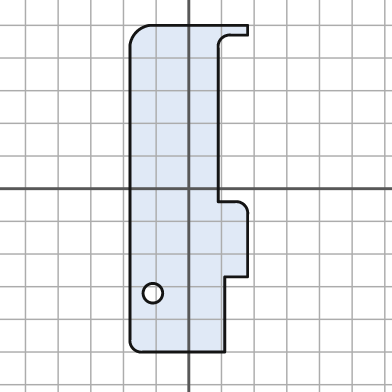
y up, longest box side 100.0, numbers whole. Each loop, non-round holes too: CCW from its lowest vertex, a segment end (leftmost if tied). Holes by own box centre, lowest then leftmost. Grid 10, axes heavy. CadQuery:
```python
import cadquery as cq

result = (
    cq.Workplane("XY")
    .moveTo(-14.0, -50.0)
    .lineTo(11.0, -50.0)
    .lineTo(11.0, -27.0)
    .lineTo(18.0, -27.0)
    .lineTo(18.0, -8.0)
    .threePointArc((17.0, -5.0), (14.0, -4.0))
    .lineTo(9.0, -4.0)
    .lineTo(9.0, 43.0)
    .threePointArc((10.0, 46.0), (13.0, 47.0))
    .lineTo(18.0, 47.0)
    .lineTo(18.0, 50.0)
    .lineTo(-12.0, 50.0)
    .threePointArc((-16.0, 48.0), (-18.0, 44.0))
    .lineTo(-18.0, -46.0)
    .threePointArc((-17.0, -49.0), (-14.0, -50.0))
    .close()
    .moveTo(-11.0, -32.0)
    .circle(3.0)
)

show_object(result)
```